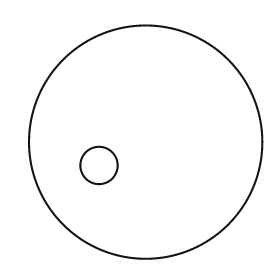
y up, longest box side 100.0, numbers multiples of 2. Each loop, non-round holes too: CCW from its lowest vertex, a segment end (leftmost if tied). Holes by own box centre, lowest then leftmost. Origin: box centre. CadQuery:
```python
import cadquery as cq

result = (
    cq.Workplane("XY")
    .moveTo(0.0, 0.0)
    .circle(50.0)
    .moveTo(-20.0, -10.0)
    .circle(8.0)
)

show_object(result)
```